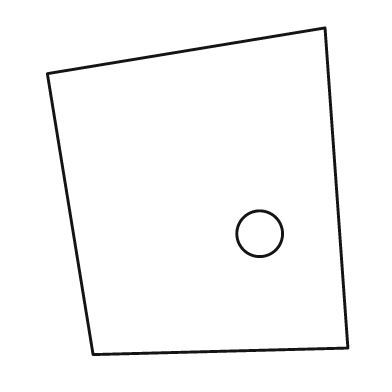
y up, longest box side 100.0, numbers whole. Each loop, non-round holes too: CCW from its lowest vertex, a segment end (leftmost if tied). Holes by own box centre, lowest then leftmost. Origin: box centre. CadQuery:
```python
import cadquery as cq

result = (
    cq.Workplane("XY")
    .moveTo(-32.0, -50.0)
    .lineTo(46.0, -48.0)
    .lineTo(39.0, 50.0)
    .lineTo(-46.0, 36.0)
    .close()
    .moveTo(19.0, -13.0)
    .circle(7.0)
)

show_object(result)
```